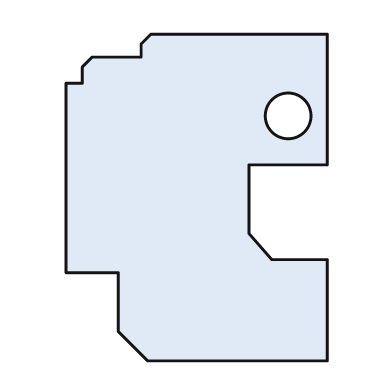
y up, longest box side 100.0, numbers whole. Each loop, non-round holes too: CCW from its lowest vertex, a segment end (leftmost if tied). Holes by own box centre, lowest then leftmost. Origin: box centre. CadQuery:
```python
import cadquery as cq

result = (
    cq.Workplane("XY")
    .moveTo(-15.0, -50.0)
    .lineTo(40.0, -50.0)
    .lineTo(40.0, -19.0)
    .lineTo(23.0, -19.0)
    .lineTo(16.0, -11.0)
    .lineTo(16.0, 10.0)
    .lineTo(40.0, 10.0)
    .lineTo(40.0, 50.0)
    .lineTo(-14.0, 50.0)
    .lineTo(-17.0, 47.0)
    .lineTo(-17.0, 43.0)
    .lineTo(-32.0, 43.0)
    .lineTo(-35.0, 40.0)
    .lineTo(-35.0, 35.0)
    .lineTo(-40.0, 35.0)
    .lineTo(-40.0, -23.0)
    .lineTo(-24.0, -23.0)
    .lineTo(-24.0, -41.0)
    .close()
    .moveTo(28.0, 25.0)
    .circle(7.0)
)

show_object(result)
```